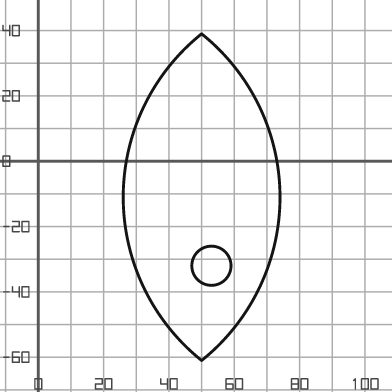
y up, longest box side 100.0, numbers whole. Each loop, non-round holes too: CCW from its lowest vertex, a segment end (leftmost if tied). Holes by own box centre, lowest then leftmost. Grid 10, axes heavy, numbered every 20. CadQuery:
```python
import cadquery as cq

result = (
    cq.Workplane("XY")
    .moveTo(50.0, -61.0)
    .threePointArc((74.0, -11.0), (50.0, 39.0))
    .threePointArc((26.0, -11.0), (50.0, -61.0))
    .close()
    .moveTo(53.0, -32.0)
    .circle(6.0)
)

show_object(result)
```